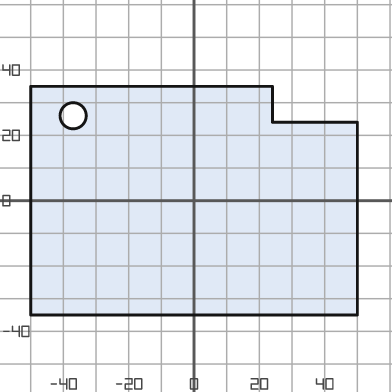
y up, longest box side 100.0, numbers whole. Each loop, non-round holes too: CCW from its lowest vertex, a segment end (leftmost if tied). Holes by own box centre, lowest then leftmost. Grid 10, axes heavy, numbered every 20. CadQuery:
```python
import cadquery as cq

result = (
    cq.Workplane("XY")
    .moveTo(-50.0, -35.0)
    .lineTo(50.0, -35.0)
    .lineTo(50.0, 24.0)
    .lineTo(24.0, 24.0)
    .lineTo(24.0, 35.0)
    .lineTo(-50.0, 35.0)
    .close()
    .moveTo(-37.0, 26.0)
    .circle(4.0)
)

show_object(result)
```